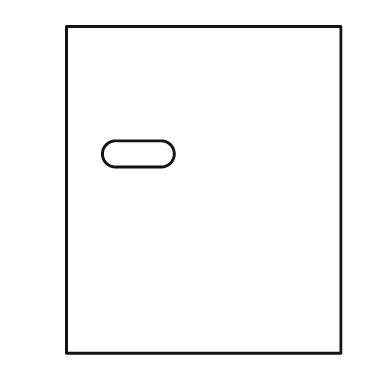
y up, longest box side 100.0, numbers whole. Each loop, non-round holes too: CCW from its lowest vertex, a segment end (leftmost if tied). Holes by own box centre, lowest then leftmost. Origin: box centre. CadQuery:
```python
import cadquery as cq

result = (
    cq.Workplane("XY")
    .moveTo(-42.0, -50.0)
    .lineTo(42.0, -50.0)
    .lineTo(42.0, 50.0)
    .lineTo(-42.0, 50.0)
    .close()
    .moveTo(-27.0, 7.0)
    .lineTo(-13.0, 7.0)
    .threePointArc((-9.0, 11.0), (-13.0, 15.0))
    .lineTo(-27.0, 15.0)
    .threePointArc((-31.0, 11.0), (-27.0, 7.0))
    .close()
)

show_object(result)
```